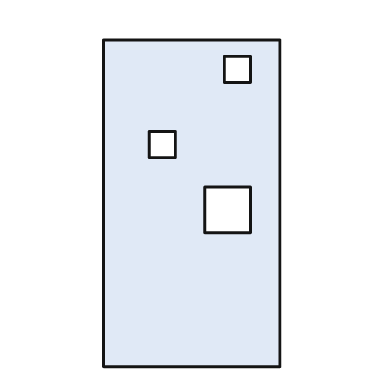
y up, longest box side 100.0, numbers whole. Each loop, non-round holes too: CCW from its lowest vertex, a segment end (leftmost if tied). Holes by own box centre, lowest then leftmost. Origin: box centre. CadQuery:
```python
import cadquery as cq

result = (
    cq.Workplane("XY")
    .moveTo(-27.0, -50.0)
    .lineTo(27.0, -50.0)
    .lineTo(27.0, 50.0)
    .lineTo(-27.0, 50.0)
    .close()
    .moveTo(4.0, -9.0)
    .lineTo(18.0, -9.0)
    .lineTo(18.0, 5.0)
    .lineTo(4.0, 5.0)
    .close()
    .moveTo(-13.0, 14.0)
    .lineTo(-5.0, 14.0)
    .lineTo(-5.0, 22.0)
    .lineTo(-13.0, 22.0)
    .close()
    .moveTo(10.0, 37.0)
    .lineTo(18.0, 37.0)
    .lineTo(18.0, 45.0)
    .lineTo(10.0, 45.0)
    .close()
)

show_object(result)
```